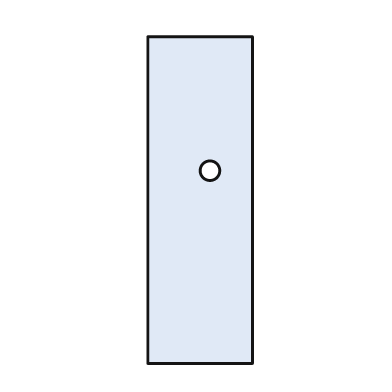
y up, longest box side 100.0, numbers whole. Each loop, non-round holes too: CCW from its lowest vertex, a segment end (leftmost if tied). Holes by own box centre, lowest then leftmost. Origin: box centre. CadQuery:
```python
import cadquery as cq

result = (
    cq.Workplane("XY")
    .moveTo(-16.0, -50.0)
    .lineTo(16.0, -50.0)
    .lineTo(16.0, 50.0)
    .lineTo(-16.0, 50.0)
    .close()
    .moveTo(3.0, 9.0)
    .circle(3.0)
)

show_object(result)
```